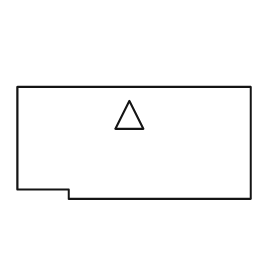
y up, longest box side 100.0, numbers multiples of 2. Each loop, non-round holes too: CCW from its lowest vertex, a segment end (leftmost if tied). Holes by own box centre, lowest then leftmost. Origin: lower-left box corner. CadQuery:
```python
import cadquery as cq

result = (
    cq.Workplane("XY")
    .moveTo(22.0, 0.0)
    .lineTo(100.0, 0.0)
    .lineTo(100.0, 48.0)
    .lineTo(0.0, 48.0)
    .lineTo(0.0, 4.0)
    .lineTo(22.0, 4.0)
    .close()
    .moveTo(42.0, 30.0)
    .lineTo(54.0, 30.0)
    .lineTo(48.0, 42.0)
    .close()
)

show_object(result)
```